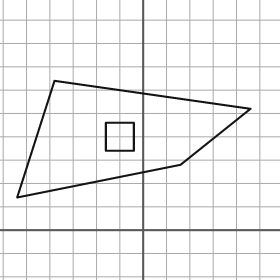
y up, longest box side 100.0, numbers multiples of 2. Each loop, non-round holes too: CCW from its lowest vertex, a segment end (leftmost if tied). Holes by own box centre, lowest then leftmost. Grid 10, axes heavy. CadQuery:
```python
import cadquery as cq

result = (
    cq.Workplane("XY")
    .moveTo(-54.0, 14.0)
    .lineTo(16.0, 28.0)
    .lineTo(46.0, 52.0)
    .lineTo(-38.0, 64.0)
    .close()
    .moveTo(-16.0, 34.0)
    .lineTo(-4.0, 34.0)
    .lineTo(-4.0, 46.0)
    .lineTo(-16.0, 46.0)
    .close()
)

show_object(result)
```